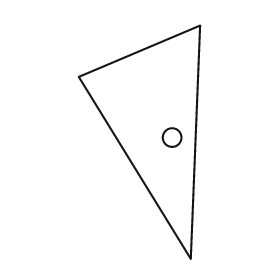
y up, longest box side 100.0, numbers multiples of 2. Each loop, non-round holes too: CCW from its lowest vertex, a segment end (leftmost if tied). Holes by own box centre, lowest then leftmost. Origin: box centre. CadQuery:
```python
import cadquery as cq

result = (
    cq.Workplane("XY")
    .moveTo(22.0, -50.0)
    .lineTo(26.0, 50.0)
    .lineTo(-26.0, 28.0)
    .close()
    .moveTo(14.0, 2.0)
    .circle(4.0)
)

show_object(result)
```